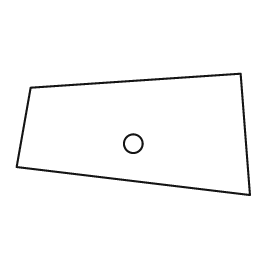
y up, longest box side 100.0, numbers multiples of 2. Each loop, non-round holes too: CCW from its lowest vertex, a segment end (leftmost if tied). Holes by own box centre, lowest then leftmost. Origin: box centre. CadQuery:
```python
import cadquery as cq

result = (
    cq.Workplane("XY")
    .moveTo(50.0, -26.0)
    .lineTo(46.0, 26.0)
    .lineTo(-44.0, 20.0)
    .lineTo(-50.0, -14.0)
    .close()
    .moveTo(0.0, -4.0)
    .circle(4.0)
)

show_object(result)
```